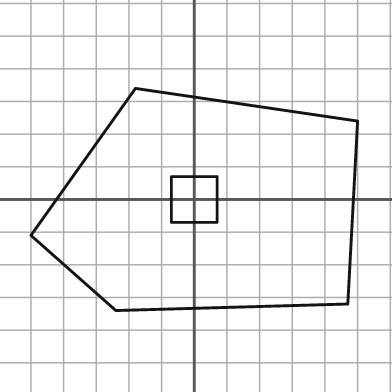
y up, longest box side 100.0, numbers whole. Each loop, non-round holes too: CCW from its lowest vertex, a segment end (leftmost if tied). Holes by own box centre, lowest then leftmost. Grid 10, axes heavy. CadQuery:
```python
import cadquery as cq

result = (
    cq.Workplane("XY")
    .moveTo(-24.0, -34.0)
    .lineTo(47.0, -32.0)
    .lineTo(50.0, 24.0)
    .lineTo(-18.0, 34.0)
    .lineTo(-50.0, -11.0)
    .close()
    .moveTo(-7.0, -7.0)
    .lineTo(7.0, -7.0)
    .lineTo(7.0, 7.0)
    .lineTo(-7.0, 7.0)
    .close()
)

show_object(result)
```